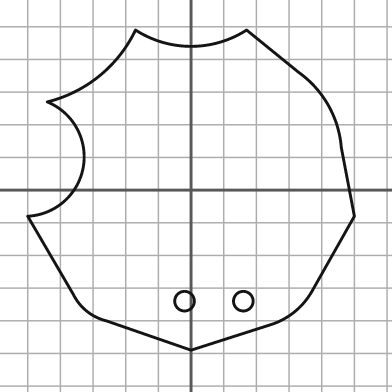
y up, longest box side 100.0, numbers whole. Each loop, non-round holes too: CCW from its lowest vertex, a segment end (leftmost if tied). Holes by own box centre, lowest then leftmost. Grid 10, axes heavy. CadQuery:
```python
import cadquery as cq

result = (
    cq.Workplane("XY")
    .moveTo(0.0, -49.0)
    .lineTo(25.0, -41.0)
    .threePointArc((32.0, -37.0), (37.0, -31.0))
    .lineTo(50.0, -8.0)
    .lineTo(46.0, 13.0)
    .threePointArc((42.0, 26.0), (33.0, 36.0))
    .lineTo(17.0, 49.0)
    .threePointArc((0.0, 44.0), (-17.0, 49.0))
    .threePointArc((-28.0, 35.0), (-44.0, 27.0))
    .threePointArc((-33.0, 7.0), (-50.0, -8.0))
    .lineTo(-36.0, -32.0)
    .threePointArc((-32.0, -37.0), (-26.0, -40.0))
    .close()
    .moveTo(-2.0, -34.0)
    .circle(3.0)
    .moveTo(16.0, -34.0)
    .circle(3.0)
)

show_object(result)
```